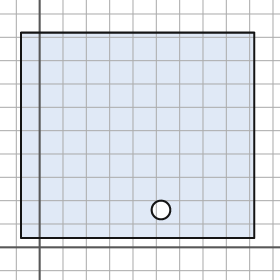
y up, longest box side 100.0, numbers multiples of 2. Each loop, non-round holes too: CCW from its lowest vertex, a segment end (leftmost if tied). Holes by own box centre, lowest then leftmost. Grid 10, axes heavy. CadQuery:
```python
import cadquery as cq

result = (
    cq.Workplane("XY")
    .moveTo(-8.0, 4.0)
    .lineTo(92.0, 4.0)
    .lineTo(92.0, 92.0)
    .lineTo(-8.0, 92.0)
    .close()
    .moveTo(52.0, 16.0)
    .circle(4.0)
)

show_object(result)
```